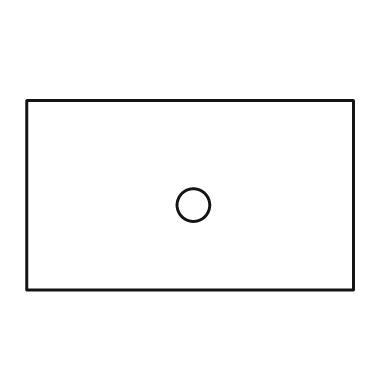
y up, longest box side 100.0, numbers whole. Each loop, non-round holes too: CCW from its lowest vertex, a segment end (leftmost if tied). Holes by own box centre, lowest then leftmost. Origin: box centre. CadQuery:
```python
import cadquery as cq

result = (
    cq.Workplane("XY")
    .moveTo(-50.0, -29.0)
    .lineTo(50.0, -29.0)
    .lineTo(50.0, 29.0)
    .lineTo(-50.0, 29.0)
    .close()
    .moveTo(1.0, -3.0)
    .circle(5.0)
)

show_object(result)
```